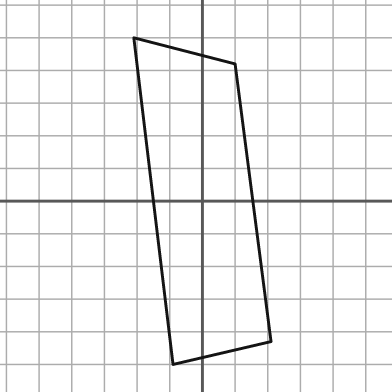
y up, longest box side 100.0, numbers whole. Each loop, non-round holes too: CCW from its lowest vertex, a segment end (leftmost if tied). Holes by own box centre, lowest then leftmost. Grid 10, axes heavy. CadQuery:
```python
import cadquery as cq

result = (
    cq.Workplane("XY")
    .moveTo(-9.0, -50.0)
    .lineTo(21.0, -43.0)
    .lineTo(10.0, 42.0)
    .lineTo(-21.0, 50.0)
    .close()
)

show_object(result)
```